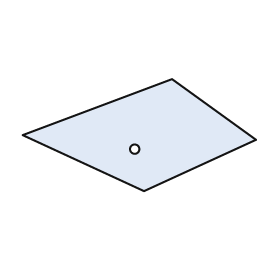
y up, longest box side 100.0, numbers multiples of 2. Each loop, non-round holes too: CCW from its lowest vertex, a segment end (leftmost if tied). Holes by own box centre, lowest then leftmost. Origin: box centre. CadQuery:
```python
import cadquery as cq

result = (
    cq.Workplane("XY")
    .moveTo(2.0, -24.0)
    .lineTo(50.0, -2.0)
    .lineTo(14.0, 24.0)
    .lineTo(-50.0, 0.0)
    .close()
    .moveTo(-2.0, -6.0)
    .circle(2.0)
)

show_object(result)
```